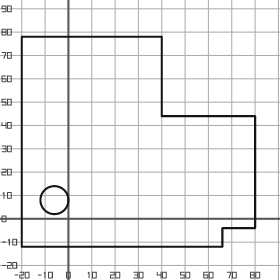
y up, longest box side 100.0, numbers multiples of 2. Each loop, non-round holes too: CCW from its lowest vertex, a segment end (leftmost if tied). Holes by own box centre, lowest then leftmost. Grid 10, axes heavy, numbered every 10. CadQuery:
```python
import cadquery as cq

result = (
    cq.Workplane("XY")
    .moveTo(-20.0, -12.0)
    .lineTo(66.0, -12.0)
    .lineTo(66.0, -4.0)
    .lineTo(80.0, -4.0)
    .lineTo(80.0, 44.0)
    .lineTo(40.0, 44.0)
    .lineTo(40.0, 78.0)
    .lineTo(-20.0, 78.0)
    .close()
    .moveTo(-6.0, 8.0)
    .circle(6.0)
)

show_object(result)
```